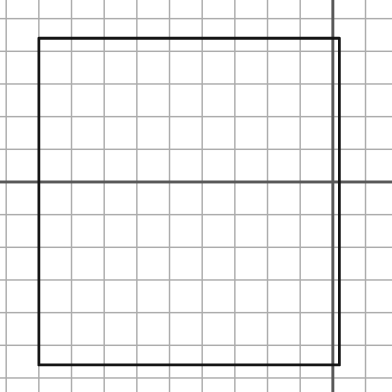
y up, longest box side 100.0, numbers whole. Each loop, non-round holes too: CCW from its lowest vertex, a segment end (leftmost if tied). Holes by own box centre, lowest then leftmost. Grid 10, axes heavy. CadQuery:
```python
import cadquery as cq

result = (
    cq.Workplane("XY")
    .moveTo(-90.0, -56.0)
    .lineTo(2.0, -56.0)
    .lineTo(2.0, 44.0)
    .lineTo(-90.0, 44.0)
    .close()
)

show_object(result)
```